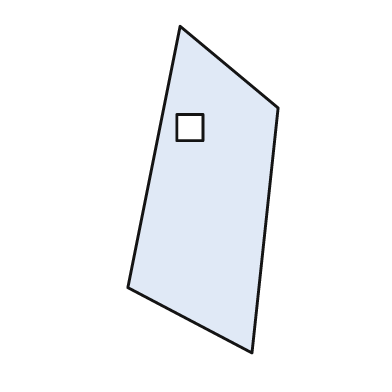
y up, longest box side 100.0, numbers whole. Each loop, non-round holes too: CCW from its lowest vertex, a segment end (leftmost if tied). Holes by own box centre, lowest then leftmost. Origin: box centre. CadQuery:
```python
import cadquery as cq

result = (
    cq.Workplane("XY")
    .moveTo(15.0, -50.0)
    .lineTo(23.0, 25.0)
    .lineTo(-7.0, 50.0)
    .lineTo(-23.0, -30.0)
    .close()
    .moveTo(-8.0, 15.0)
    .lineTo(0.0, 15.0)
    .lineTo(0.0, 23.0)
    .lineTo(-8.0, 23.0)
    .close()
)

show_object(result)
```